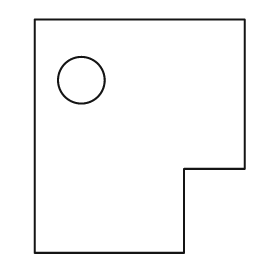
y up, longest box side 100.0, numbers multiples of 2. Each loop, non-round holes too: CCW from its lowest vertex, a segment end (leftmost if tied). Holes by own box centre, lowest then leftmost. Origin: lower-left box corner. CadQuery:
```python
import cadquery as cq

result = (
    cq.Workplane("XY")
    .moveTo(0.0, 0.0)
    .lineTo(64.0, 0.0)
    .lineTo(64.0, 36.0)
    .lineTo(90.0, 36.0)
    .lineTo(90.0, 100.0)
    .lineTo(0.0, 100.0)
    .close()
    .moveTo(20.0, 74.0)
    .circle(10.0)
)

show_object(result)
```